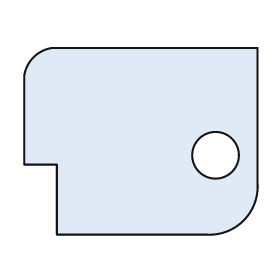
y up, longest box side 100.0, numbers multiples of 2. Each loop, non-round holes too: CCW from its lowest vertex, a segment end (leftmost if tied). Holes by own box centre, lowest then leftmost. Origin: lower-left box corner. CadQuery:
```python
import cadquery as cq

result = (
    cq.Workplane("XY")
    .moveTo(14.0, 0.0)
    .lineTo(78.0, 0.0)
    .threePointArc((94.0, 6.0), (100.0, 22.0))
    .lineTo(100.0, 80.0)
    .lineTo(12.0, 80.0)
    .threePointArc((4.0, 76.0), (0.0, 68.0))
    .lineTo(0.0, 30.0)
    .lineTo(14.0, 30.0)
    .close()
    .moveTo(82.0, 34.0)
    .circle(10.0)
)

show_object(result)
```